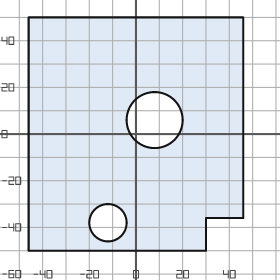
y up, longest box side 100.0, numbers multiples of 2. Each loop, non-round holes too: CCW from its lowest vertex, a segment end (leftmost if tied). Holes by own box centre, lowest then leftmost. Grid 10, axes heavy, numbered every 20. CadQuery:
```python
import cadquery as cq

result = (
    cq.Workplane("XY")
    .moveTo(-46.0, -50.0)
    .lineTo(30.0, -50.0)
    .lineTo(30.0, -36.0)
    .lineTo(46.0, -36.0)
    .lineTo(46.0, 50.0)
    .lineTo(-46.0, 50.0)
    .close()
    .moveTo(-12.0, -38.0)
    .circle(8.0)
    .moveTo(8.0, 6.0)
    .circle(12.0)
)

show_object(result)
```